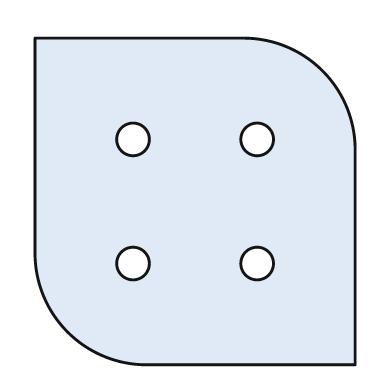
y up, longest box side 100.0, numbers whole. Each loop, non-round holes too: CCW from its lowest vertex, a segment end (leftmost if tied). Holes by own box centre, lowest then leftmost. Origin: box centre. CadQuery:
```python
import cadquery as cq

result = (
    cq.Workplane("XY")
    .moveTo(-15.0, -50.0)
    .lineTo(49.0, -50.0)
    .lineTo(49.0, 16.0)
    .threePointArc((39.0, 40.0), (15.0, 50.0))
    .lineTo(-49.0, 50.0)
    .lineTo(-49.0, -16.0)
    .threePointArc((-39.0, -40.0), (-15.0, -50.0))
    .close()
    .moveTo(-19.0, -19.0)
    .circle(5.0)
    .moveTo(19.0, -19.0)
    .circle(5.0)
    .moveTo(-19.0, 19.0)
    .circle(5.0)
    .moveTo(19.0, 19.0)
    .circle(5.0)
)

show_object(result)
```